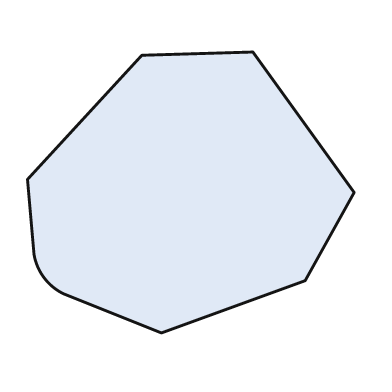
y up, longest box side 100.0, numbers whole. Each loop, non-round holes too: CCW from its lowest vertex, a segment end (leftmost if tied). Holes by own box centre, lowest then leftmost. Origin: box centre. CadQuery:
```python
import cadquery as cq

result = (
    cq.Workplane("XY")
    .moveTo(-9.0, -43.0)
    .lineTo(35.0, -27.0)
    .lineTo(50.0, 0.0)
    .lineTo(19.0, 43.0)
    .lineTo(-15.0, 42.0)
    .lineTo(-50.0, 4.0)
    .lineTo(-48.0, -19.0)
    .threePointArc((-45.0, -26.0), (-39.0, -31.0))
    .close()
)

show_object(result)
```